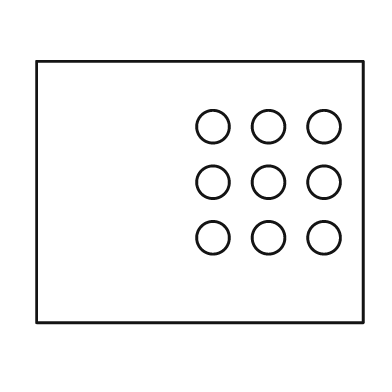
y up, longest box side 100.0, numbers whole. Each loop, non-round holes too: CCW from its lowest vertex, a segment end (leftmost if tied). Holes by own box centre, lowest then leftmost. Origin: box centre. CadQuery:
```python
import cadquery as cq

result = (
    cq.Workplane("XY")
    .moveTo(-50.0, -40.0)
    .lineTo(50.0, -40.0)
    .lineTo(50.0, 40.0)
    .lineTo(-50.0, 40.0)
    .close()
    .moveTo(4.0, -14.0)
    .circle(5.0)
    .moveTo(21.0, -14.0)
    .circle(5.0)
    .moveTo(38.0, -14.0)
    .circle(5.0)
    .moveTo(4.0, 3.0)
    .circle(5.0)
    .moveTo(21.0, 3.0)
    .circle(5.0)
    .moveTo(38.0, 3.0)
    .circle(5.0)
    .moveTo(4.0, 20.0)
    .circle(5.0)
    .moveTo(21.0, 20.0)
    .circle(5.0)
    .moveTo(38.0, 20.0)
    .circle(5.0)
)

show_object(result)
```